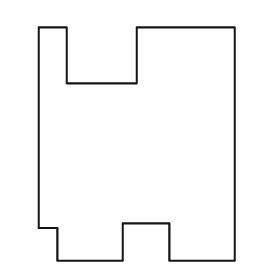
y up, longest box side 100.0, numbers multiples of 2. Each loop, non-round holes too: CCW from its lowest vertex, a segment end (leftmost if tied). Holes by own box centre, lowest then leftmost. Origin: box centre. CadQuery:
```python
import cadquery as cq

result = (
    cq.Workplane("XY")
    .moveTo(-34.0, -50.0)
    .lineTo(-6.0, -50.0)
    .lineTo(-6.0, -34.0)
    .lineTo(14.0, -34.0)
    .lineTo(14.0, -50.0)
    .lineTo(42.0, -50.0)
    .lineTo(42.0, 50.0)
    .lineTo(0.0, 50.0)
    .lineTo(0.0, 26.0)
    .lineTo(-30.0, 26.0)
    .lineTo(-30.0, 50.0)
    .lineTo(-42.0, 50.0)
    .lineTo(-42.0, -36.0)
    .lineTo(-34.0, -36.0)
    .close()
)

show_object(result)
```